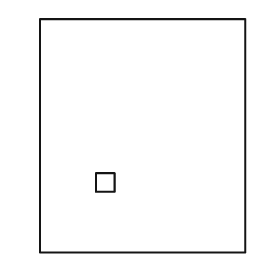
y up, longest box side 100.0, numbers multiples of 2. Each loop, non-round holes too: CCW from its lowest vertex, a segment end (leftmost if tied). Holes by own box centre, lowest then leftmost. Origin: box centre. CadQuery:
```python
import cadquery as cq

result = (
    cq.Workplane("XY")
    .moveTo(-44.0, -50.0)
    .lineTo(44.0, -50.0)
    .lineTo(44.0, 50.0)
    .lineTo(-44.0, 50.0)
    .close()
    .moveTo(-20.0, -24.0)
    .lineTo(-12.0, -24.0)
    .lineTo(-12.0, -16.0)
    .lineTo(-20.0, -16.0)
    .close()
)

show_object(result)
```